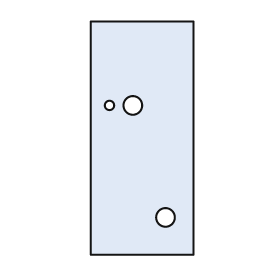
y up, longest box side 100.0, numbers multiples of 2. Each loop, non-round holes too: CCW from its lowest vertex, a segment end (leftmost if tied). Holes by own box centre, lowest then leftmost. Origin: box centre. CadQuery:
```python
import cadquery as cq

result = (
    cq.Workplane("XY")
    .moveTo(-22.0, -50.0)
    .lineTo(22.0, -50.0)
    .lineTo(22.0, 50.0)
    .lineTo(-22.0, 50.0)
    .close()
    .moveTo(10.0, -34.0)
    .circle(4.0)
    .moveTo(-14.0, 14.0)
    .circle(2.0)
    .moveTo(-4.0, 14.0)
    .circle(4.0)
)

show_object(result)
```